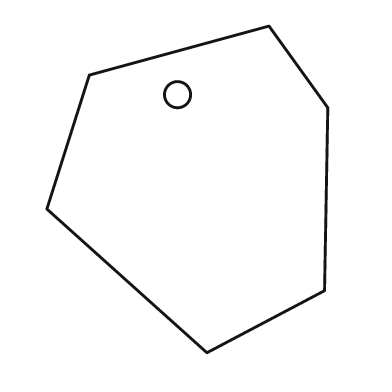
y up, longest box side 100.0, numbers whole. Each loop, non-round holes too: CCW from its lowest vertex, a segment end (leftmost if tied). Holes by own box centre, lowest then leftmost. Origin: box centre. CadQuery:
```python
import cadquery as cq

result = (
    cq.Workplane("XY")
    .moveTo(6.0, -50.0)
    .lineTo(42.0, -31.0)
    .lineTo(43.0, 25.0)
    .lineTo(25.0, 50.0)
    .lineTo(-30.0, 35.0)
    .lineTo(-43.0, -6.0)
    .close()
    .moveTo(-3.0, 29.0)
    .circle(4.0)
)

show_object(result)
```